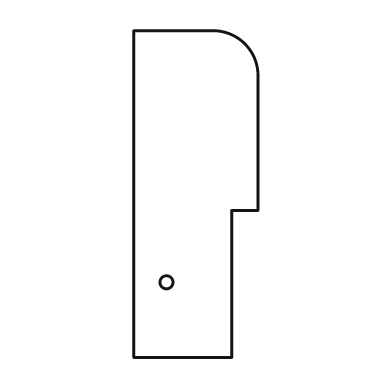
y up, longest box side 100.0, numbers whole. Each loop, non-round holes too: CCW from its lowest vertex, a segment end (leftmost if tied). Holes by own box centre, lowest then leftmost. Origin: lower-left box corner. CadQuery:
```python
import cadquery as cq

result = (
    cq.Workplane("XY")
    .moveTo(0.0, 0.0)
    .lineTo(30.0, 0.0)
    .lineTo(30.0, 45.0)
    .lineTo(38.0, 45.0)
    .lineTo(38.0, 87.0)
    .threePointArc((34.0, 96.0), (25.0, 100.0))
    .lineTo(0.0, 100.0)
    .close()
    .moveTo(10.0, 23.0)
    .circle(2.0)
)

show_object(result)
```